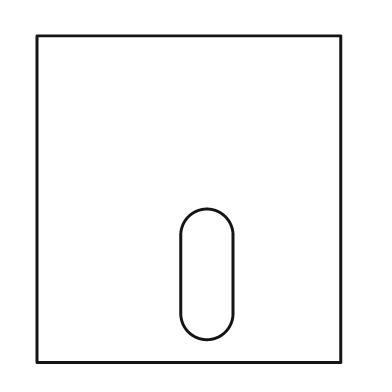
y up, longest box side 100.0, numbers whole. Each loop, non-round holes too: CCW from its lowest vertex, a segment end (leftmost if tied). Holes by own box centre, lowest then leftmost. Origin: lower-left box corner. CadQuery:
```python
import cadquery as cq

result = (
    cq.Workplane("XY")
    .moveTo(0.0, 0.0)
    .lineTo(93.0, 0.0)
    .lineTo(93.0, 100.0)
    .lineTo(0.0, 100.0)
    .close()
    .moveTo(44.0, 15.0)
    .threePointArc((52.0, 7.0), (60.0, 15.0))
    .lineTo(60.0, 39.0)
    .threePointArc((52.0, 47.0), (44.0, 39.0))
    .close()
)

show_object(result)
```